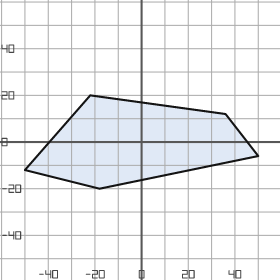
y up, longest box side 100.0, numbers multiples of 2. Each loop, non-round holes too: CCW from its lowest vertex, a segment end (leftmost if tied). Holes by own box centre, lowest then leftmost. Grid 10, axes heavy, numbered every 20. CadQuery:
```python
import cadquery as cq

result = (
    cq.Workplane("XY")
    .moveTo(-18.0, -20.0)
    .lineTo(50.0, -6.0)
    .lineTo(36.0, 12.0)
    .lineTo(-22.0, 20.0)
    .lineTo(-50.0, -12.0)
    .close()
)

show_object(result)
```